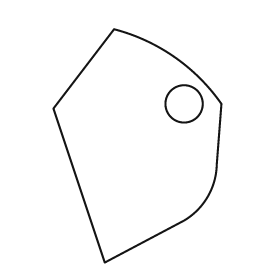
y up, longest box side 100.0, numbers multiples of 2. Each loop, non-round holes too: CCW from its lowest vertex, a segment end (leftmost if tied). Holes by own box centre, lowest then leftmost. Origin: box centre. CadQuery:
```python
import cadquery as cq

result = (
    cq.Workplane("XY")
    .moveTo(-14.0, -50.0)
    .lineTo(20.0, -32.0)
    .threePointArc((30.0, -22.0), (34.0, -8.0))
    .lineTo(36.0, 18.0)
    .threePointArc((16.0, 38.0), (-10.0, 50.0))
    .lineTo(-36.0, 16.0)
    .close()
    .moveTo(20.0, 18.0)
    .circle(8.0)
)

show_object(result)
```